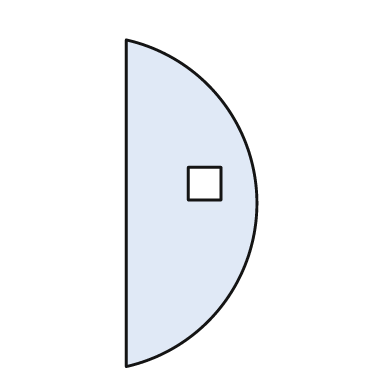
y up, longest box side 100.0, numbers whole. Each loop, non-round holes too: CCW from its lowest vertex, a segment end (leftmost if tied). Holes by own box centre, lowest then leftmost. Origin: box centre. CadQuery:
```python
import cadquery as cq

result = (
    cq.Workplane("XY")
    .moveTo(-20.0, -50.0)
    .threePointArc((20.0, 0.0), (-20.0, 50.0))
    .close()
    .moveTo(-1.0, 1.0)
    .lineTo(9.0, 1.0)
    .lineTo(9.0, 11.0)
    .lineTo(-1.0, 11.0)
    .close()
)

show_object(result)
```